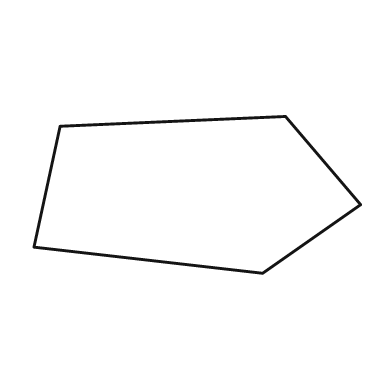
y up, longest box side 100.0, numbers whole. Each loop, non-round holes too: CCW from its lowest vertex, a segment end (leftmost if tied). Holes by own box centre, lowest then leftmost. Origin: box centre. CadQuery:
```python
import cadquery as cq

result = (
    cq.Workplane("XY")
    .moveTo(20.0, -24.0)
    .lineTo(50.0, -3.0)
    .lineTo(27.0, 24.0)
    .lineTo(-42.0, 21.0)
    .lineTo(-50.0, -16.0)
    .close()
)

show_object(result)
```